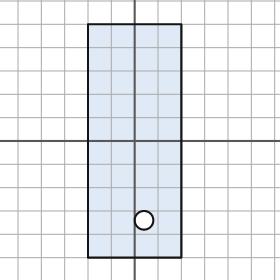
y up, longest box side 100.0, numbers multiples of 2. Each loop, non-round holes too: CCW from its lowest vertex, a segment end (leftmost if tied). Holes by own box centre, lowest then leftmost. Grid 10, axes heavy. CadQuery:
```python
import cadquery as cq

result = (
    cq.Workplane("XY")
    .moveTo(-20.0, -50.0)
    .lineTo(20.0, -50.0)
    .lineTo(20.0, 50.0)
    .lineTo(-20.0, 50.0)
    .close()
    .moveTo(4.0, -34.0)
    .circle(4.0)
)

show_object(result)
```